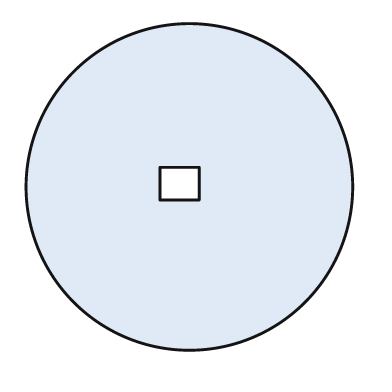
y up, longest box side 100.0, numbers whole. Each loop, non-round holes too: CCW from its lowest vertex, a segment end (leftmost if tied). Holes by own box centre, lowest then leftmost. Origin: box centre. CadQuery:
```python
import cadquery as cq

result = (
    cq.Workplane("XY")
    .moveTo(0.0, 0.0)
    .circle(50.0)
    .moveTo(-9.0, -4.0)
    .lineTo(3.0, -4.0)
    .lineTo(3.0, 6.0)
    .lineTo(-9.0, 6.0)
    .close()
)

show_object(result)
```